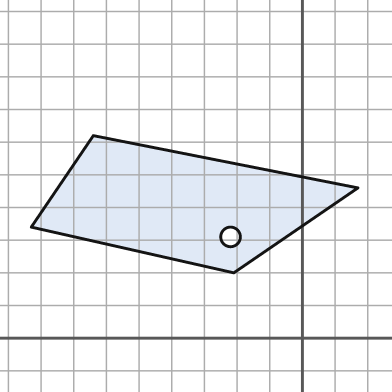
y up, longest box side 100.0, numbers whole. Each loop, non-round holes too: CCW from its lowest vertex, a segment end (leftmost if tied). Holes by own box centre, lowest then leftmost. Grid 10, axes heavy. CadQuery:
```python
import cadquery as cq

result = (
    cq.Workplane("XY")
    .moveTo(-21.0, 20.0)
    .lineTo(17.0, 46.0)
    .lineTo(-64.0, 62.0)
    .lineTo(-83.0, 34.0)
    .close()
    .moveTo(-22.0, 31.0)
    .circle(3.0)
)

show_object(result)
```